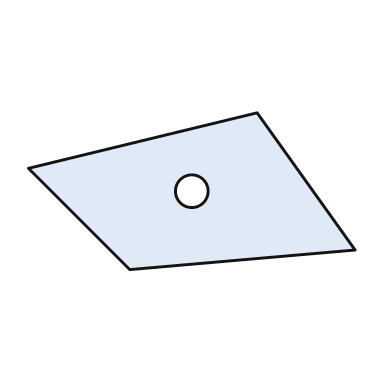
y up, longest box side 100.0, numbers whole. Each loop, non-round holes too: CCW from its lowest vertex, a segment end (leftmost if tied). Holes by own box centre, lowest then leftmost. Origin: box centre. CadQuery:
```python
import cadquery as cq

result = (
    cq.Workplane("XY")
    .moveTo(-19.0, -24.0)
    .lineTo(50.0, -18.0)
    .lineTo(20.0, 24.0)
    .lineTo(-50.0, 7.0)
    .close()
    .moveTo(0.0, 0.0)
    .circle(5.0)
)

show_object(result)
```